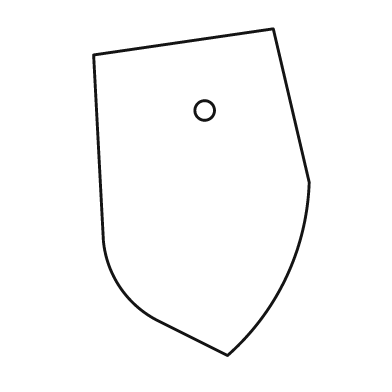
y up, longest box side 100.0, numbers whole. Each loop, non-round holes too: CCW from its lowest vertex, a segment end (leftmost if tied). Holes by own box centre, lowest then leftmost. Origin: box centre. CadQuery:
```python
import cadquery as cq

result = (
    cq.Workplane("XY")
    .moveTo(8.0, -50.0)
    .threePointArc((26.0, -26.0), (33.0, 3.0))
    .lineTo(22.0, 50.0)
    .lineTo(-33.0, 42.0)
    .lineTo(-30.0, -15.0)
    .threePointArc((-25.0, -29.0), (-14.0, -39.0))
    .close()
    .moveTo(1.0, 25.0)
    .circle(3.0)
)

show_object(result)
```